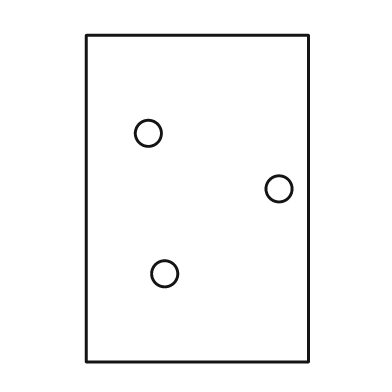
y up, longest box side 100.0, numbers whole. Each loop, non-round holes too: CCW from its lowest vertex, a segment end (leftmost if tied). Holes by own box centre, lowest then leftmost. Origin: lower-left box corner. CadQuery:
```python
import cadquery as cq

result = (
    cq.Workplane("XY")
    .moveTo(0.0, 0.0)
    .lineTo(68.0, 0.0)
    .lineTo(68.0, 100.0)
    .lineTo(0.0, 100.0)
    .close()
    .moveTo(24.0, 27.0)
    .circle(4.0)
    .moveTo(59.0, 53.0)
    .circle(4.0)
    .moveTo(19.0, 70.0)
    .circle(4.0)
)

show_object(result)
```